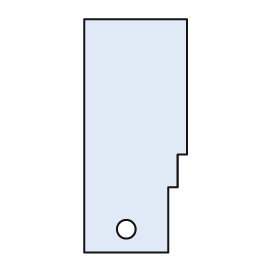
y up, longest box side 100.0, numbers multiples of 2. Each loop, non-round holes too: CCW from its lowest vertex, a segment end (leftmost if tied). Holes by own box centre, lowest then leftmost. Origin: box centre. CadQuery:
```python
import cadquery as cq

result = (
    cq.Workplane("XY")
    .moveTo(-22.0, -50.0)
    .lineTo(14.0, -50.0)
    .lineTo(14.0, -22.0)
    .lineTo(18.0, -22.0)
    .lineTo(18.0, -8.0)
    .lineTo(22.0, -8.0)
    .lineTo(22.0, 50.0)
    .lineTo(-22.0, 50.0)
    .close()
    .moveTo(-4.0, -40.0)
    .circle(4.0)
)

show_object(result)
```